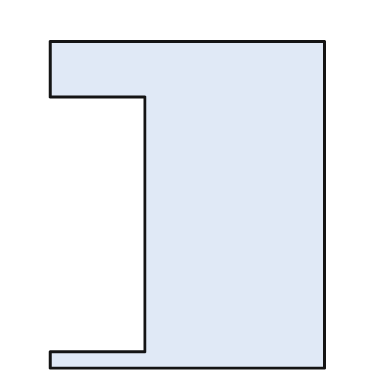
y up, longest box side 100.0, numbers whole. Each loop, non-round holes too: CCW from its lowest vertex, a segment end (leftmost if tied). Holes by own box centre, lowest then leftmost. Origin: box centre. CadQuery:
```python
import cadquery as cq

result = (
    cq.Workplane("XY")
    .moveTo(-42.0, -50.0)
    .lineTo(42.0, -50.0)
    .lineTo(42.0, 50.0)
    .lineTo(-42.0, 50.0)
    .lineTo(-42.0, 33.0)
    .lineTo(-13.0, 33.0)
    .lineTo(-13.0, -45.0)
    .lineTo(-42.0, -45.0)
    .close()
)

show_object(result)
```